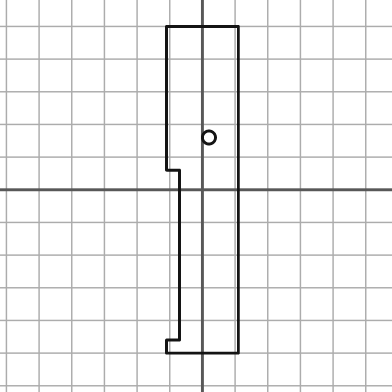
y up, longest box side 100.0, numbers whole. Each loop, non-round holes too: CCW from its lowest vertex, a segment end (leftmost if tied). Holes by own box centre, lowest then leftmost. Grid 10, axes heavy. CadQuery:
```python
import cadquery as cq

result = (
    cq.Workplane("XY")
    .moveTo(-11.0, -50.0)
    .lineTo(11.0, -50.0)
    .lineTo(11.0, 50.0)
    .lineTo(-11.0, 50.0)
    .lineTo(-11.0, 6.0)
    .lineTo(-7.0, 6.0)
    .lineTo(-7.0, -46.0)
    .lineTo(-11.0, -46.0)
    .close()
    .moveTo(2.0, 16.0)
    .circle(2.0)
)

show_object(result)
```